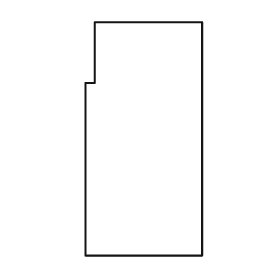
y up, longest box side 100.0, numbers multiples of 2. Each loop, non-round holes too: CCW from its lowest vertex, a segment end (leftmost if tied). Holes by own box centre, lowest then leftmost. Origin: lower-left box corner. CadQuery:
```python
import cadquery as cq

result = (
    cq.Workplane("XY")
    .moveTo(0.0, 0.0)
    .lineTo(50.0, 0.0)
    .lineTo(50.0, 100.0)
    .lineTo(4.0, 100.0)
    .lineTo(4.0, 74.0)
    .lineTo(0.0, 74.0)
    .close()
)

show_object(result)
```